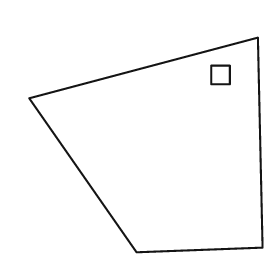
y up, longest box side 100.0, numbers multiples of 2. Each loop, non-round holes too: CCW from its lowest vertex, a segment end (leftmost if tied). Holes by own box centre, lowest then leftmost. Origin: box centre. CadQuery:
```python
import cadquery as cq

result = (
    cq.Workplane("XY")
    .moveTo(-4.0, -46.0)
    .lineTo(50.0, -44.0)
    .lineTo(48.0, 46.0)
    .lineTo(-50.0, 20.0)
    .close()
    .moveTo(28.0, 26.0)
    .lineTo(36.0, 26.0)
    .lineTo(36.0, 34.0)
    .lineTo(28.0, 34.0)
    .close()
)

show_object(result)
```